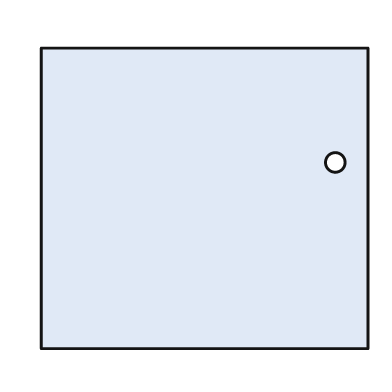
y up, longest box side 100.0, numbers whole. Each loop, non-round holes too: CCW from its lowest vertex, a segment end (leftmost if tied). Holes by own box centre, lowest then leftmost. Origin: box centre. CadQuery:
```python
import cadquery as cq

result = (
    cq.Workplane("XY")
    .moveTo(-50.0, -46.0)
    .lineTo(50.0, -46.0)
    .lineTo(50.0, 46.0)
    .lineTo(-50.0, 46.0)
    .close()
    .moveTo(40.0, 11.0)
    .circle(3.0)
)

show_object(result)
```